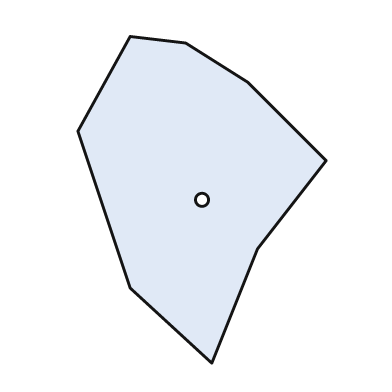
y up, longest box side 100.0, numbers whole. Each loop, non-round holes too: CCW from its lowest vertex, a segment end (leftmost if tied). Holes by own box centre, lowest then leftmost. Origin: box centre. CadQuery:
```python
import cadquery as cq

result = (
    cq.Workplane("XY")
    .moveTo(3.0, -50.0)
    .lineTo(17.0, -15.0)
    .lineTo(38.0, 12.0)
    .lineTo(14.0, 36.0)
    .lineTo(-5.0, 48.0)
    .lineTo(-22.0, 50.0)
    .lineTo(-38.0, 21.0)
    .lineTo(-22.0, -27.0)
    .close()
    .moveTo(0.0, 0.0)
    .circle(2.0)
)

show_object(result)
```